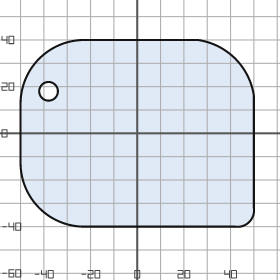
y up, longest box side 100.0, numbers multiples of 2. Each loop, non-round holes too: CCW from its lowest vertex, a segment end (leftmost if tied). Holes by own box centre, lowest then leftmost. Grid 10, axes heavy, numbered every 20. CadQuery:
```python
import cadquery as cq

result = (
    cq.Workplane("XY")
    .moveTo(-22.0, -40.0)
    .lineTo(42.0, -40.0)
    .threePointArc((48.0, -38.0), (50.0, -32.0))
    .lineTo(50.0, 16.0)
    .threePointArc((42.0, 32.0), (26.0, 40.0))
    .lineTo(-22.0, 40.0)
    .threePointArc((-42.0, 32.0), (-50.0, 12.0))
    .lineTo(-50.0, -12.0)
    .threePointArc((-42.0, -32.0), (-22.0, -40.0))
    .close()
    .moveTo(-38.0, 18.0)
    .circle(4.0)
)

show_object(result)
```